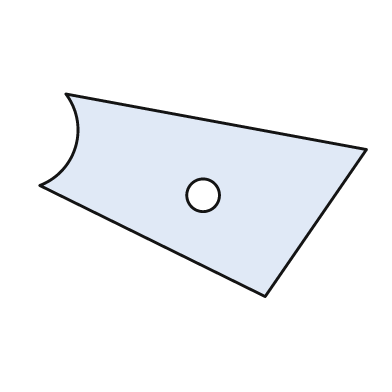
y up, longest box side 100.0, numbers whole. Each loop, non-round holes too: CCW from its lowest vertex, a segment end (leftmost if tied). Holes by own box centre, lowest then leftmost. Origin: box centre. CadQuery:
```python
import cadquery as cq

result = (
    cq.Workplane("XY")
    .moveTo(19.0, -31.0)
    .lineTo(50.0, 14.0)
    .lineTo(-42.0, 31.0)
    .threePointArc((-39.0, 15.0), (-50.0, 3.0))
    .close()
    .moveTo(0.0, 0.0)
    .circle(5.0)
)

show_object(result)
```